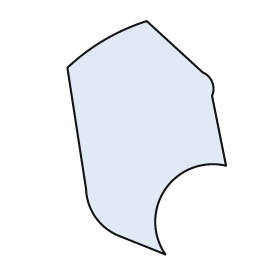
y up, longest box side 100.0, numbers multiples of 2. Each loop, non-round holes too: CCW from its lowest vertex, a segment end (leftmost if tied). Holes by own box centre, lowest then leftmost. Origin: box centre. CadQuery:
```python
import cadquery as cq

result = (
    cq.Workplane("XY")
    .moveTo(8.0, -50.0)
    .threePointArc((8.0, -22.0), (34.0, -12.0))
    .lineTo(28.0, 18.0)
    .threePointArc((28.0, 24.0), (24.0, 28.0))
    .lineTo(0.0, 50.0)
    .threePointArc((-18.0, 42.0), (-34.0, 30.0))
    .lineTo(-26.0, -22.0)
    .threePointArc((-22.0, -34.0), (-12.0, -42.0))
    .close()
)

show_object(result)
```